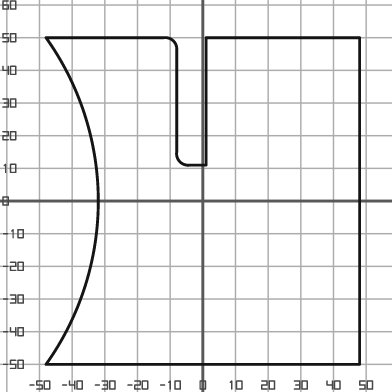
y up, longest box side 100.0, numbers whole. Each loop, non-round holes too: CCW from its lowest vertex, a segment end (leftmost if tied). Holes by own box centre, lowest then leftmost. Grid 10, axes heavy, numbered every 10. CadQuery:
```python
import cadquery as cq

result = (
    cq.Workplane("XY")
    .moveTo(-48.0, -50.0)
    .lineTo(48.0, -50.0)
    .lineTo(48.0, 50.0)
    .lineTo(1.0, 50.0)
    .lineTo(1.0, 11.0)
    .lineTo(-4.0, 11.0)
    .threePointArc((-7.0, 12.0), (-8.0, 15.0))
    .lineTo(-8.0, 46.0)
    .threePointArc((-9.0, 49.0), (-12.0, 50.0))
    .lineTo(-48.0, 50.0)
    .threePointArc((-32.0, 0.0), (-48.0, -50.0))
    .close()
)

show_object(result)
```